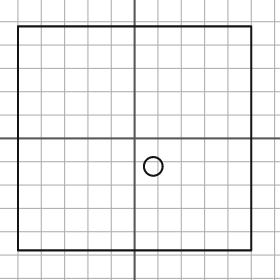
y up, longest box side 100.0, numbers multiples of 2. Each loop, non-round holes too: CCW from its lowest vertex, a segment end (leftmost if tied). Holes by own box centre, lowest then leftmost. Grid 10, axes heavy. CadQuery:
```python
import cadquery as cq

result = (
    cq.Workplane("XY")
    .moveTo(-50.0, -48.0)
    .lineTo(50.0, -48.0)
    .lineTo(50.0, 48.0)
    .lineTo(-50.0, 48.0)
    .close()
    .moveTo(8.0, -12.0)
    .circle(4.0)
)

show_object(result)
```